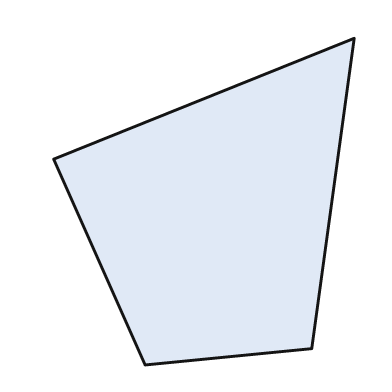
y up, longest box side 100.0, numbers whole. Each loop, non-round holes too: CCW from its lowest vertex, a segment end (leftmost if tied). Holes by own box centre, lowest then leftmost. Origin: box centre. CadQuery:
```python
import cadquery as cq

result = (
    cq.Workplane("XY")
    .moveTo(-18.0, -50.0)
    .lineTo(33.0, -45.0)
    .lineTo(46.0, 50.0)
    .lineTo(-46.0, 13.0)
    .close()
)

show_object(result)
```